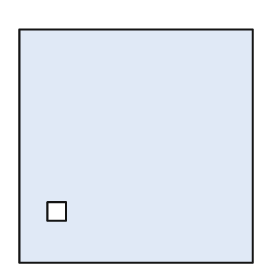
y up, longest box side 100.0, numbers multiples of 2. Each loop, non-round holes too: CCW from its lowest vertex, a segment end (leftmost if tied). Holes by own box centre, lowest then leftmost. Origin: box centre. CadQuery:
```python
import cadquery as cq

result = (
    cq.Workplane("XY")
    .moveTo(-50.0, -50.0)
    .lineTo(50.0, -50.0)
    .lineTo(50.0, 50.0)
    .lineTo(-50.0, 50.0)
    .close()
    .moveTo(-38.0, -32.0)
    .lineTo(-30.0, -32.0)
    .lineTo(-30.0, -24.0)
    .lineTo(-38.0, -24.0)
    .close()
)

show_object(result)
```